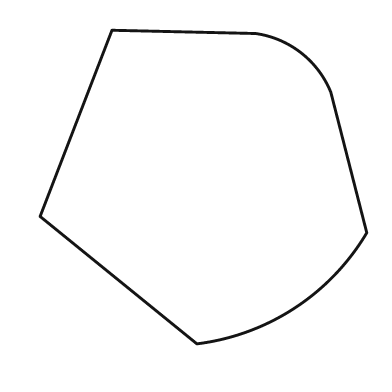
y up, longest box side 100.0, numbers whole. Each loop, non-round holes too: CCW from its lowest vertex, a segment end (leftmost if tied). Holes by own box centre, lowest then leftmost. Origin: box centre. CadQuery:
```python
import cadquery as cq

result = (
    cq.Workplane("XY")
    .moveTo(-2.0, -48.0)
    .threePointArc((28.0, -37.0), (50.0, -14.0))
    .lineTo(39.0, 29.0)
    .threePointArc((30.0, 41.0), (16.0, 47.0))
    .lineTo(-28.0, 48.0)
    .lineTo(-50.0, -9.0)
    .close()
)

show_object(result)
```